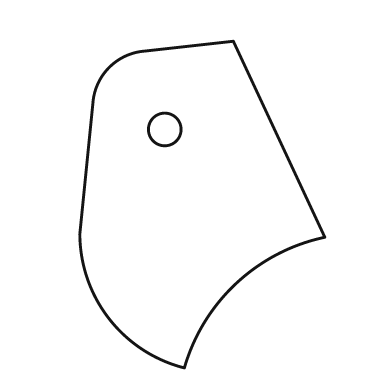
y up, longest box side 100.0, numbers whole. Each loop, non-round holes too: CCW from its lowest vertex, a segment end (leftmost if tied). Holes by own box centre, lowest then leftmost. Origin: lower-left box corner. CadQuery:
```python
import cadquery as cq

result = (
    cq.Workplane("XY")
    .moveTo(32.0, 0.0)
    .threePointArc((48.0, 26.0), (75.0, 40.0))
    .lineTo(47.0, 100.0)
    .lineTo(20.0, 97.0)
    .threePointArc((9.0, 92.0), (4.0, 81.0))
    .lineTo(0.0, 41.0)
    .threePointArc((9.0, 15.0), (32.0, 0.0))
    .close()
    .moveTo(26.0, 73.0)
    .circle(5.0)
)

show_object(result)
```